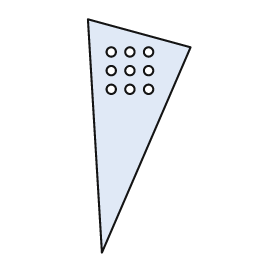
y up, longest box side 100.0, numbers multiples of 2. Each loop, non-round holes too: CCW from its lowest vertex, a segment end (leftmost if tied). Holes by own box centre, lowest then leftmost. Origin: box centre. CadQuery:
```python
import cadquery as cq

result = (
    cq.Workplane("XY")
    .moveTo(-16.0, -50.0)
    .lineTo(22.0, 38.0)
    .lineTo(-22.0, 50.0)
    .close()
    .moveTo(-12.0, 20.0)
    .circle(2.0)
    .moveTo(-4.0, 20.0)
    .circle(2.0)
    .moveTo(4.0, 20.0)
    .circle(2.0)
    .moveTo(-12.0, 28.0)
    .circle(2.0)
    .moveTo(-4.0, 28.0)
    .circle(2.0)
    .moveTo(4.0, 28.0)
    .circle(2.0)
    .moveTo(-12.0, 36.0)
    .circle(2.0)
    .moveTo(-4.0, 36.0)
    .circle(2.0)
    .moveTo(4.0, 36.0)
    .circle(2.0)
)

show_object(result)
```